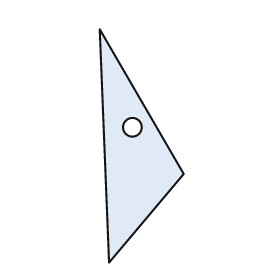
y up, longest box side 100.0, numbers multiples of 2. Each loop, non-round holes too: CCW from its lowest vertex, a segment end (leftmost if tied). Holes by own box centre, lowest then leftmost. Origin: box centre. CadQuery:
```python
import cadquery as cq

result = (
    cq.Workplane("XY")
    .moveTo(-14.0, -50.0)
    .lineTo(18.0, -12.0)
    .lineTo(-18.0, 50.0)
    .close()
    .moveTo(-4.0, 8.0)
    .circle(4.0)
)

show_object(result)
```